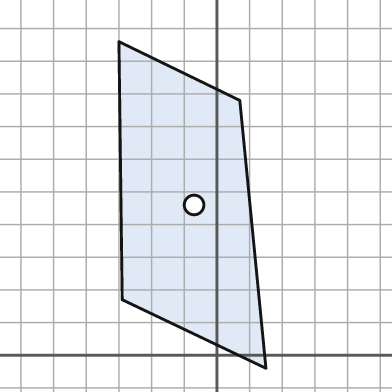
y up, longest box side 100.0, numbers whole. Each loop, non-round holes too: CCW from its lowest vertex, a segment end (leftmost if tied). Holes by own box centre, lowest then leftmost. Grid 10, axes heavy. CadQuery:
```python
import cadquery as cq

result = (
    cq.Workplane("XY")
    .moveTo(15.0, -4.0)
    .lineTo(7.0, 78.0)
    .lineTo(-30.0, 96.0)
    .lineTo(-29.0, 17.0)
    .close()
    .moveTo(-7.0, 46.0)
    .circle(3.0)
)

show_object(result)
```